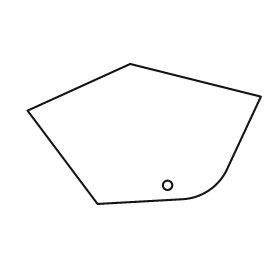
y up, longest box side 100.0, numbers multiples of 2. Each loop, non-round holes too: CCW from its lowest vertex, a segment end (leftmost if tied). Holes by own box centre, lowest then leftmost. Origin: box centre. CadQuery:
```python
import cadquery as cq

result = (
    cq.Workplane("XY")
    .moveTo(-20.0, -30.0)
    .lineTo(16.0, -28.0)
    .threePointArc((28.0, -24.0), (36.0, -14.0))
    .lineTo(50.0, 16.0)
    .lineTo(-6.0, 30.0)
    .lineTo(-50.0, 10.0)
    .close()
    .moveTo(10.0, -22.0)
    .circle(2.0)
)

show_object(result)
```